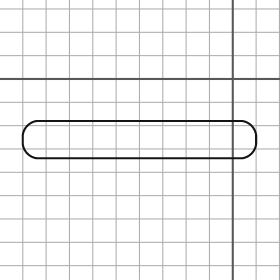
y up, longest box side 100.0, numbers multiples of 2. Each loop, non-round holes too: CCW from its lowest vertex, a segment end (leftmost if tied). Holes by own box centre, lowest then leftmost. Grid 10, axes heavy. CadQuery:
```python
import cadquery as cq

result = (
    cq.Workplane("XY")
    .moveTo(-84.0, -34.0)
    .lineTo(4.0, -34.0)
    .threePointArc((8.0, -32.0), (10.0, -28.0))
    .lineTo(10.0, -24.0)
    .threePointArc((8.0, -20.0), (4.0, -18.0))
    .lineTo(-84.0, -18.0)
    .threePointArc((-88.0, -20.0), (-90.0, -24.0))
    .lineTo(-90.0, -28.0)
    .threePointArc((-88.0, -32.0), (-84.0, -34.0))
    .close()
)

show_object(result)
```